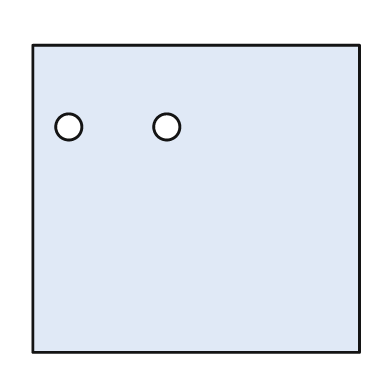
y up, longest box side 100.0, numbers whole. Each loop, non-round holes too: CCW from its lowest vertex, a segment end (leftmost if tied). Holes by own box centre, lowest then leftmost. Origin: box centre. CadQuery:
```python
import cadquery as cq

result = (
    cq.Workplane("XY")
    .moveTo(-50.0, -47.0)
    .lineTo(50.0, -47.0)
    .lineTo(50.0, 47.0)
    .lineTo(-50.0, 47.0)
    .close()
    .moveTo(-39.0, 22.0)
    .circle(4.0)
    .moveTo(-9.0, 22.0)
    .circle(4.0)
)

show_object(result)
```